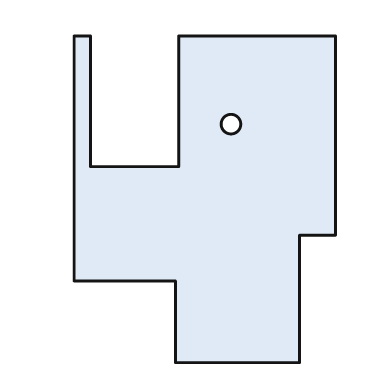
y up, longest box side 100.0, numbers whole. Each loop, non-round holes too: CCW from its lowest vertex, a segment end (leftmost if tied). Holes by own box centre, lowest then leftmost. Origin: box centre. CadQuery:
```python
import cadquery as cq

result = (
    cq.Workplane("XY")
    .moveTo(-9.0, -50.0)
    .lineTo(29.0, -50.0)
    .lineTo(29.0, -11.0)
    .lineTo(40.0, -11.0)
    .lineTo(40.0, 50.0)
    .lineTo(-8.0, 50.0)
    .lineTo(-8.0, 10.0)
    .lineTo(-35.0, 10.0)
    .lineTo(-35.0, 50.0)
    .lineTo(-40.0, 50.0)
    .lineTo(-40.0, -25.0)
    .lineTo(-9.0, -25.0)
    .close()
    .moveTo(8.0, 23.0)
    .circle(3.0)
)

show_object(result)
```